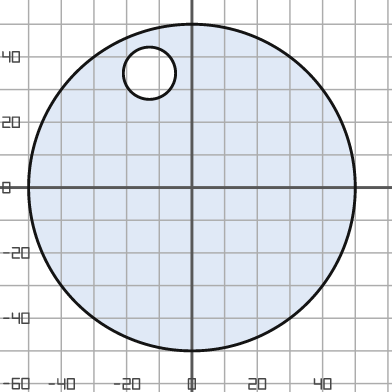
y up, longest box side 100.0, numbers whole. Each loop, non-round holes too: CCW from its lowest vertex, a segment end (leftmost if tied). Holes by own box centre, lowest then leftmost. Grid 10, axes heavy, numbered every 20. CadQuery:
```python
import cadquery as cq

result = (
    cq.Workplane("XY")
    .moveTo(0.0, 0.0)
    .circle(50.0)
    .moveTo(-13.0, 35.0)
    .circle(8.0)
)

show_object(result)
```